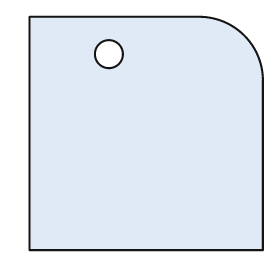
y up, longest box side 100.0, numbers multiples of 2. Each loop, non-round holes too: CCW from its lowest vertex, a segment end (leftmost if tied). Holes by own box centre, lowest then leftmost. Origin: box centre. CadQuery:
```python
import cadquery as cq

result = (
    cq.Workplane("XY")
    .moveTo(-50.0, -50.0)
    .lineTo(50.0, -50.0)
    .lineTo(50.0, 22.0)
    .threePointArc((42.0, 42.0), (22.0, 50.0))
    .lineTo(-50.0, 50.0)
    .close()
    .moveTo(-16.0, 34.0)
    .circle(6.0)
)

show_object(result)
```